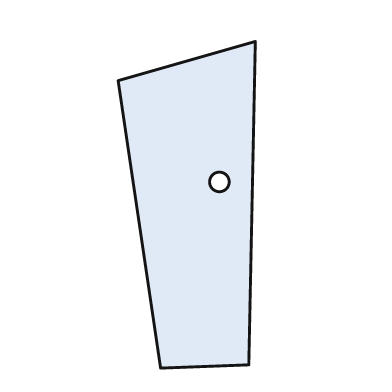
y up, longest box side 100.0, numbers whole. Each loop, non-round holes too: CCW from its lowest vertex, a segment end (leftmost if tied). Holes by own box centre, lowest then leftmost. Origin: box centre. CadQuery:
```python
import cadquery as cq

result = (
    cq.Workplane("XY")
    .moveTo(-8.0, -50.0)
    .lineTo(19.0, -49.0)
    .lineTo(21.0, 50.0)
    .lineTo(-21.0, 38.0)
    .close()
    .moveTo(10.0, 7.0)
    .circle(3.0)
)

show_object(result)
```